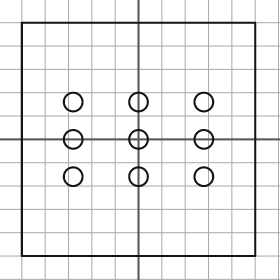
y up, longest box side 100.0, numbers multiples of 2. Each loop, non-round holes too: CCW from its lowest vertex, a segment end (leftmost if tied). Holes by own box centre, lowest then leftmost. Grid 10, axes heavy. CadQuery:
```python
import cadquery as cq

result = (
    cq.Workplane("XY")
    .moveTo(-50.0, -50.0)
    .lineTo(50.0, -50.0)
    .lineTo(50.0, 50.0)
    .lineTo(-50.0, 50.0)
    .close()
    .moveTo(-28.0, -16.0)
    .circle(4.0)
    .moveTo(0.0, -16.0)
    .circle(4.0)
    .moveTo(28.0, -16.0)
    .circle(4.0)
    .moveTo(-28.0, 0.0)
    .circle(4.0)
    .moveTo(0.0, 0.0)
    .circle(4.0)
    .moveTo(28.0, 0.0)
    .circle(4.0)
    .moveTo(-28.0, 16.0)
    .circle(4.0)
    .moveTo(0.0, 16.0)
    .circle(4.0)
    .moveTo(28.0, 16.0)
    .circle(4.0)
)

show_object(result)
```